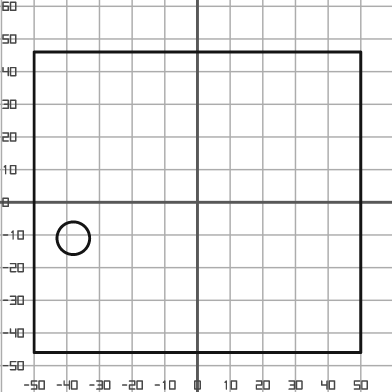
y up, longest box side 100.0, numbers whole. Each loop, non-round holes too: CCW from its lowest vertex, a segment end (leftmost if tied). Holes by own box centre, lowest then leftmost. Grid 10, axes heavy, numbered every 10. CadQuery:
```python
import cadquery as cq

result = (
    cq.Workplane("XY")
    .moveTo(-50.0, -46.0)
    .lineTo(50.0, -46.0)
    .lineTo(50.0, 46.0)
    .lineTo(-50.0, 46.0)
    .close()
    .moveTo(-38.0, -11.0)
    .circle(5.0)
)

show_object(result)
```